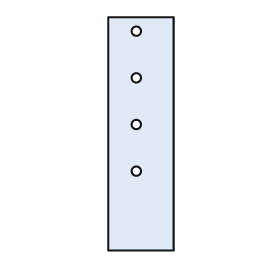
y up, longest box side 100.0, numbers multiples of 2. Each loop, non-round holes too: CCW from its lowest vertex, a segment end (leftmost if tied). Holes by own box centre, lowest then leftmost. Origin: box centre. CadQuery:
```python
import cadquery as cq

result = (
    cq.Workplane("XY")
    .moveTo(-14.0, -50.0)
    .lineTo(14.0, -50.0)
    .lineTo(14.0, 50.0)
    .lineTo(-14.0, 50.0)
    .close()
    .moveTo(-2.0, -16.0)
    .circle(2.0)
    .moveTo(-2.0, 4.0)
    .circle(2.0)
    .moveTo(-2.0, 24.0)
    .circle(2.0)
    .moveTo(-2.0, 44.0)
    .circle(2.0)
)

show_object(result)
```